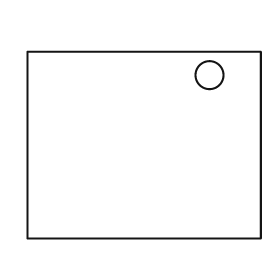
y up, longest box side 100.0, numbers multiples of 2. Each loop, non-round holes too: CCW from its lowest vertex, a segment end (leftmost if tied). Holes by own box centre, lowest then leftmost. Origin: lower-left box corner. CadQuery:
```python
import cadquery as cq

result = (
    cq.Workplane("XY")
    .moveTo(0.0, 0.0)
    .lineTo(100.0, 0.0)
    .lineTo(100.0, 80.0)
    .lineTo(0.0, 80.0)
    .close()
    .moveTo(78.0, 70.0)
    .circle(6.0)
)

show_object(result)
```